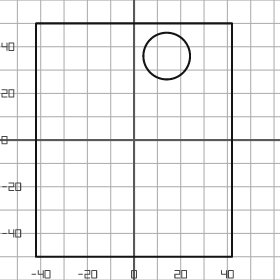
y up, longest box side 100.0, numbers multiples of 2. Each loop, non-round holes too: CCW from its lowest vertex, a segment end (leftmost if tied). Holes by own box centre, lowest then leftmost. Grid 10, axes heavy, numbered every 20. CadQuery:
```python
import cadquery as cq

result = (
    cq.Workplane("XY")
    .moveTo(-42.0, -50.0)
    .lineTo(42.0, -50.0)
    .lineTo(42.0, 50.0)
    .lineTo(-42.0, 50.0)
    .close()
    .moveTo(14.0, 36.0)
    .circle(10.0)
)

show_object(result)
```